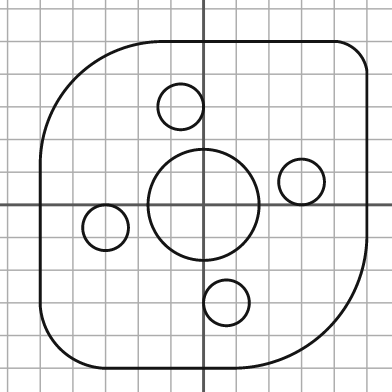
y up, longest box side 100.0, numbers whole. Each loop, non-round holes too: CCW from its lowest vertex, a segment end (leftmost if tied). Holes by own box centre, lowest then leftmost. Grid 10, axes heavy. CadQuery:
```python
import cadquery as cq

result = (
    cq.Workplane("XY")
    .moveTo(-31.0, -50.0)
    .lineTo(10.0, -50.0)
    .threePointArc((38.0, -38.0), (50.0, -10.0))
    .lineTo(50.0, 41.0)
    .threePointArc((47.0, 47.0), (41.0, 50.0))
    .lineTo(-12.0, 50.0)
    .threePointArc((-39.0, 39.0), (-50.0, 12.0))
    .lineTo(-50.0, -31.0)
    .threePointArc((-44.0, -44.0), (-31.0, -50.0))
    .close()
    .moveTo(7.0, -30.0)
    .circle(7.0)
    .moveTo(-30.0, -7.0)
    .circle(7.0)
    .moveTo(0.0, 0.0)
    .circle(17.0)
    .moveTo(30.0, 7.0)
    .circle(7.0)
    .moveTo(-7.0, 30.0)
    .circle(7.0)
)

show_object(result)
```